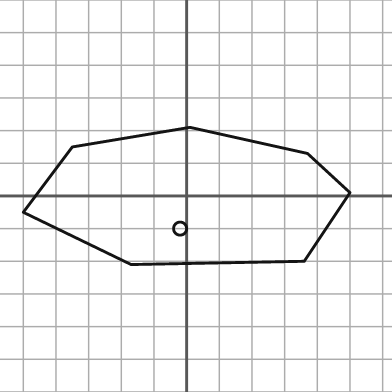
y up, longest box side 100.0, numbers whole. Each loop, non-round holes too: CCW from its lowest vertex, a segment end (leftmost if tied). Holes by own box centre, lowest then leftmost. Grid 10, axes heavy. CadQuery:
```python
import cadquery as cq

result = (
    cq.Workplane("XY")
    .moveTo(-17.0, -21.0)
    .lineTo(36.0, -20.0)
    .lineTo(50.0, 1.0)
    .lineTo(37.0, 13.0)
    .lineTo(1.0, 21.0)
    .lineTo(-35.0, 15.0)
    .lineTo(-50.0, -5.0)
    .close()
    .moveTo(-2.0, -10.0)
    .circle(2.0)
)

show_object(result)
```